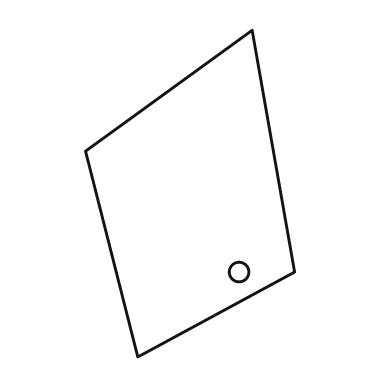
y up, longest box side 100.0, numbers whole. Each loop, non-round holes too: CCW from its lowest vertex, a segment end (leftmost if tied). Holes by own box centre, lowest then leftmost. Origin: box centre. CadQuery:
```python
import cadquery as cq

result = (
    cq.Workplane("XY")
    .moveTo(-16.0, -50.0)
    .lineTo(32.0, -24.0)
    .lineTo(19.0, 50.0)
    .lineTo(-32.0, 13.0)
    .close()
    .moveTo(15.0, -24.0)
    .circle(3.0)
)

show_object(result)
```